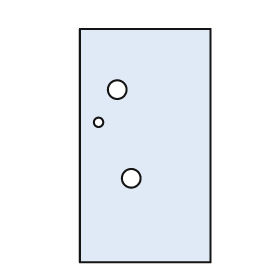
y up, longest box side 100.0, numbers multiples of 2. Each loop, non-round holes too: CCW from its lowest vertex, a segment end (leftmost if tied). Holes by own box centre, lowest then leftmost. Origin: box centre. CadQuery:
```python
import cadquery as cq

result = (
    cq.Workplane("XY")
    .moveTo(-28.0, -50.0)
    .lineTo(28.0, -50.0)
    .lineTo(28.0, 50.0)
    .lineTo(-28.0, 50.0)
    .close()
    .moveTo(-6.0, -14.0)
    .circle(4.0)
    .moveTo(-20.0, 10.0)
    .circle(2.0)
    .moveTo(-12.0, 24.0)
    .circle(4.0)
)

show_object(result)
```